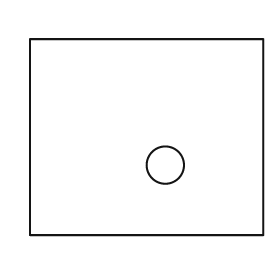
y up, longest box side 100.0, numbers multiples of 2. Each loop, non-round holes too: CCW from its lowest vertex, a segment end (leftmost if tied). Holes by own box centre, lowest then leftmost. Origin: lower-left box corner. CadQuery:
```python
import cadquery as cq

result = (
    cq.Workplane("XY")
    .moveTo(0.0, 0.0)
    .lineTo(100.0, 0.0)
    .lineTo(100.0, 84.0)
    .lineTo(0.0, 84.0)
    .close()
    .moveTo(58.0, 30.0)
    .circle(8.0)
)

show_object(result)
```